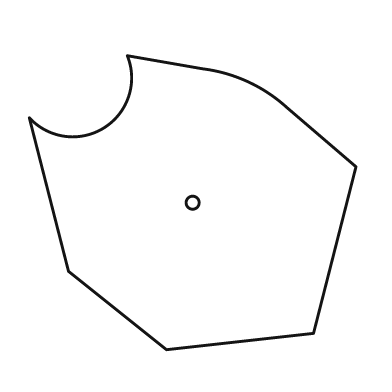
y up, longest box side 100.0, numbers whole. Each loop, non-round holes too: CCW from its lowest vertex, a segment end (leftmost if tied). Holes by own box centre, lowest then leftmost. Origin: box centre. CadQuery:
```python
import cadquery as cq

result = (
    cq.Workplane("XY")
    .moveTo(-8.0, -45.0)
    .lineTo(37.0, -40.0)
    .lineTo(50.0, 11.0)
    .lineTo(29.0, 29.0)
    .threePointArc((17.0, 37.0), (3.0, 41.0))
    .lineTo(-20.0, 45.0)
    .threePointArc((-27.0, 23.0), (-50.0, 26.0))
    .lineTo(-38.0, -21.0)
    .close()
    .moveTo(0.0, 0.0)
    .circle(2.0)
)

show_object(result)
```